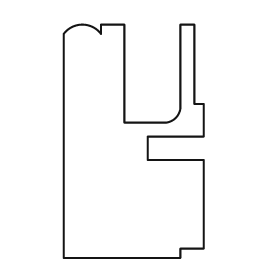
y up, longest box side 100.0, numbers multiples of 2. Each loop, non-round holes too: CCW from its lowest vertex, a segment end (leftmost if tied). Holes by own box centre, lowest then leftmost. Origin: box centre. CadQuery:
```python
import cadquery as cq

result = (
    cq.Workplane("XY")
    .moveTo(-30.0, -50.0)
    .lineTo(20.0, -50.0)
    .lineTo(20.0, -46.0)
    .lineTo(30.0, -46.0)
    .lineTo(30.0, -8.0)
    .lineTo(6.0, -8.0)
    .lineTo(6.0, 2.0)
    .lineTo(30.0, 2.0)
    .lineTo(30.0, 16.0)
    .lineTo(26.0, 16.0)
    .lineTo(26.0, 50.0)
    .lineTo(20.0, 50.0)
    .lineTo(20.0, 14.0)
    .threePointArc((18.0, 10.0), (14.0, 8.0))
    .lineTo(-4.0, 8.0)
    .lineTo(-4.0, 50.0)
    .lineTo(-14.0, 50.0)
    .lineTo(-14.0, 46.0)
    .threePointArc((-22.0, 50.0), (-30.0, 46.0))
    .close()
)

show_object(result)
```